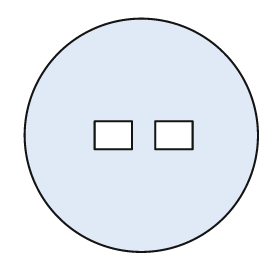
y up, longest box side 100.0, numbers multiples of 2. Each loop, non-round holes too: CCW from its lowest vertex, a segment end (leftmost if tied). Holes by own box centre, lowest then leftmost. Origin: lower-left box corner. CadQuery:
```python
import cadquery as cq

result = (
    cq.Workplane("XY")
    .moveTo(50.0, 50.0)
    .circle(50.0)
    .moveTo(30.0, 44.0)
    .lineTo(46.0, 44.0)
    .lineTo(46.0, 56.0)
    .lineTo(30.0, 56.0)
    .close()
    .moveTo(56.0, 44.0)
    .lineTo(72.0, 44.0)
    .lineTo(72.0, 56.0)
    .lineTo(56.0, 56.0)
    .close()
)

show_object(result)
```